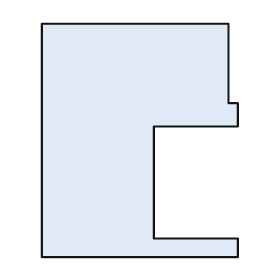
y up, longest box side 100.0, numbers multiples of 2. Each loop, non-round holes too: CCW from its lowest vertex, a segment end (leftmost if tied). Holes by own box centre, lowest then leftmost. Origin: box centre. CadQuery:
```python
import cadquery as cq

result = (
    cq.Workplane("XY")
    .moveTo(-42.0, -50.0)
    .lineTo(42.0, -50.0)
    .lineTo(42.0, -42.0)
    .lineTo(6.0, -42.0)
    .lineTo(6.0, 6.0)
    .lineTo(42.0, 6.0)
    .lineTo(42.0, 16.0)
    .lineTo(38.0, 16.0)
    .lineTo(38.0, 50.0)
    .lineTo(-42.0, 50.0)
    .close()
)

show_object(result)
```